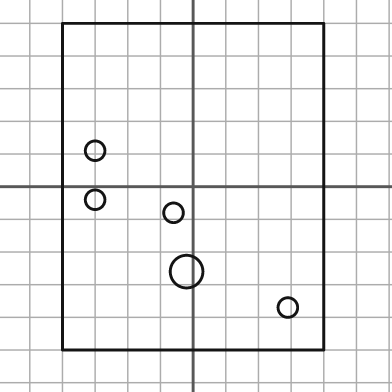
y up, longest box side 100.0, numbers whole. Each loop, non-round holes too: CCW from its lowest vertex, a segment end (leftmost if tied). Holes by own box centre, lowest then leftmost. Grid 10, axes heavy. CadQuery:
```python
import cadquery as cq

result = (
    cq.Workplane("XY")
    .moveTo(-40.0, -50.0)
    .lineTo(40.0, -50.0)
    .lineTo(40.0, 50.0)
    .lineTo(-40.0, 50.0)
    .close()
    .moveTo(29.0, -37.0)
    .circle(3.0)
    .moveTo(-2.0, -26.0)
    .circle(5.0)
    .moveTo(-6.0, -8.0)
    .circle(3.0)
    .moveTo(-30.0, -4.0)
    .circle(3.0)
    .moveTo(-30.0, 11.0)
    .circle(3.0)
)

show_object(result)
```